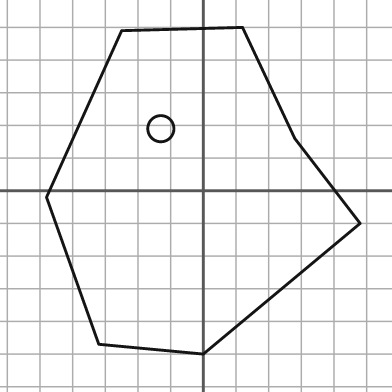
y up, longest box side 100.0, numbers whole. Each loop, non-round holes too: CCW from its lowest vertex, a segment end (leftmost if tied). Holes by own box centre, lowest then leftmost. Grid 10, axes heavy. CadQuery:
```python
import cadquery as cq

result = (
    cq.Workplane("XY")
    .moveTo(0.0, -50.0)
    .lineTo(48.0, -10.0)
    .lineTo(28.0, 16.0)
    .lineTo(12.0, 50.0)
    .lineTo(-25.0, 49.0)
    .lineTo(-48.0, -2.0)
    .lineTo(-32.0, -47.0)
    .close()
    .moveTo(-13.0, 19.0)
    .circle(4.0)
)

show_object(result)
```